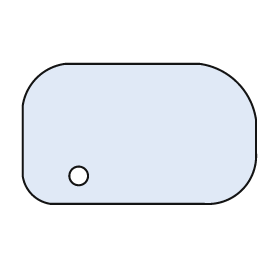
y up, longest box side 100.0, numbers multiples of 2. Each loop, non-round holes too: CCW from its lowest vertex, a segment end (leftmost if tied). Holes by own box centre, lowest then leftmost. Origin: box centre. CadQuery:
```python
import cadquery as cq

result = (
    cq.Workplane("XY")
    .moveTo(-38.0, -30.0)
    .lineTo(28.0, -30.0)
    .threePointArc((44.0, -24.0), (50.0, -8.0))
    .lineTo(50.0, 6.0)
    .threePointArc((42.0, 22.0), (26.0, 30.0))
    .lineTo(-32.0, 30.0)
    .threePointArc((-44.0, 24.0), (-50.0, 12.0))
    .lineTo(-50.0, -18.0)
    .threePointArc((-46.0, -26.0), (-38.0, -30.0))
    .close()
    .moveTo(-26.0, -18.0)
    .circle(4.0)
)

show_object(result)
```